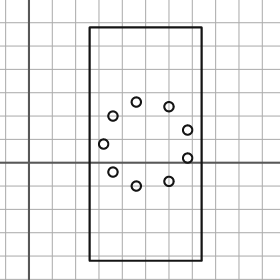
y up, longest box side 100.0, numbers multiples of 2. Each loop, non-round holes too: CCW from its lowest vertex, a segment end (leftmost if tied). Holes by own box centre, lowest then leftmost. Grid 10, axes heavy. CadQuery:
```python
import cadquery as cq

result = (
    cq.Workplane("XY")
    .moveTo(26.0, -42.0)
    .lineTo(74.0, -42.0)
    .lineTo(74.0, 58.0)
    .lineTo(26.0, 58.0)
    .close()
    .moveTo(46.0, -10.0)
    .circle(2.0)
    .moveTo(60.0, -8.0)
    .circle(2.0)
    .moveTo(36.0, -4.0)
    .circle(2.0)
    .moveTo(68.0, 2.0)
    .circle(2.0)
    .moveTo(32.0, 8.0)
    .circle(2.0)
    .moveTo(68.0, 14.0)
    .circle(2.0)
    .moveTo(36.0, 20.0)
    .circle(2.0)
    .moveTo(60.0, 24.0)
    .circle(2.0)
    .moveTo(46.0, 26.0)
    .circle(2.0)
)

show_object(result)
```